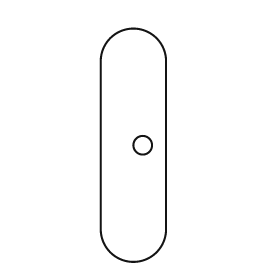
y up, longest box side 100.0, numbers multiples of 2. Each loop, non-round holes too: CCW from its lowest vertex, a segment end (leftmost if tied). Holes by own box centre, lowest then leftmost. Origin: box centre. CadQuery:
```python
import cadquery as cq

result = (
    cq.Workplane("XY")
    .moveTo(-14.0, -36.0)
    .threePointArc((0.0, -50.0), (14.0, -36.0))
    .lineTo(14.0, 36.0)
    .threePointArc((0.0, 50.0), (-14.0, 36.0))
    .close()
    .moveTo(4.0, 0.0)
    .circle(4.0)
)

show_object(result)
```